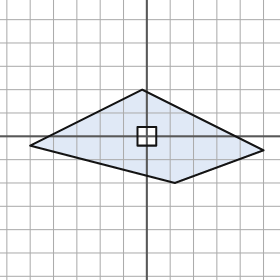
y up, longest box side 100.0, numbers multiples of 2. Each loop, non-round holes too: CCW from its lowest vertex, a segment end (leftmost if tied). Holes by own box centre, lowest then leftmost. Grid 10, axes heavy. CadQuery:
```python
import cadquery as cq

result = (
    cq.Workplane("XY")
    .moveTo(12.0, -20.0)
    .lineTo(50.0, -6.0)
    .lineTo(-2.0, 20.0)
    .lineTo(-50.0, -4.0)
    .close()
    .moveTo(-4.0, -4.0)
    .lineTo(4.0, -4.0)
    .lineTo(4.0, 4.0)
    .lineTo(-4.0, 4.0)
    .close()
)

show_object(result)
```